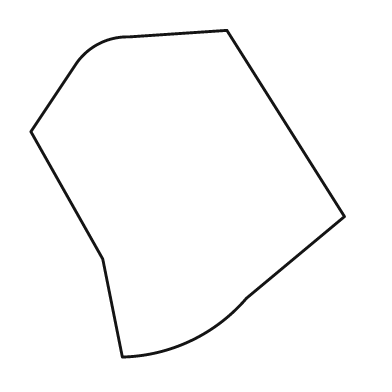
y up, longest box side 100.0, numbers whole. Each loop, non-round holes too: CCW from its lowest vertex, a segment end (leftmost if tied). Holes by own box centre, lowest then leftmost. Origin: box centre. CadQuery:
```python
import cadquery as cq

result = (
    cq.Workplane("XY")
    .moveTo(-20.0, -50.0)
    .threePointArc((1.0, -45.0), (18.0, -32.0))
    .lineTo(48.0, -7.0)
    .lineTo(12.0, 50.0)
    .lineTo(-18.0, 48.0)
    .threePointArc((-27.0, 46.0), (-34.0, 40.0))
    .lineTo(-48.0, 19.0)
    .lineTo(-26.0, -20.0)
    .close()
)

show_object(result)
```